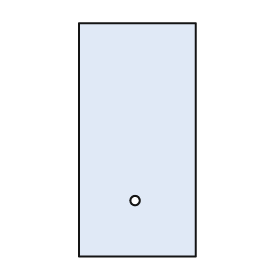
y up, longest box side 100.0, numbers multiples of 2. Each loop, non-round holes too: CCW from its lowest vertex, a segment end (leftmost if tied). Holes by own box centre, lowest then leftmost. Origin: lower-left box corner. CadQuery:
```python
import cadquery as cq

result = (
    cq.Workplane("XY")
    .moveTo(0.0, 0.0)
    .lineTo(50.0, 0.0)
    .lineTo(50.0, 100.0)
    .lineTo(0.0, 100.0)
    .close()
    .moveTo(24.0, 24.0)
    .circle(2.0)
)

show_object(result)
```